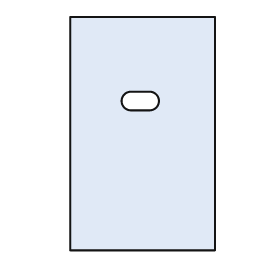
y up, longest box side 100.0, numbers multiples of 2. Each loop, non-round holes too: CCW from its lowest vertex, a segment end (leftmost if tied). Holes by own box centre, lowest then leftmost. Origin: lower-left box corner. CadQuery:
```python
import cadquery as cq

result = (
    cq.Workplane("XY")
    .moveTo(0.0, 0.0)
    .lineTo(62.0, 0.0)
    .lineTo(62.0, 100.0)
    .lineTo(0.0, 100.0)
    .close()
    .moveTo(26.0, 60.0)
    .lineTo(34.0, 60.0)
    .threePointArc((38.0, 64.0), (34.0, 68.0))
    .lineTo(26.0, 68.0)
    .threePointArc((22.0, 64.0), (26.0, 60.0))
    .close()
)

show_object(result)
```